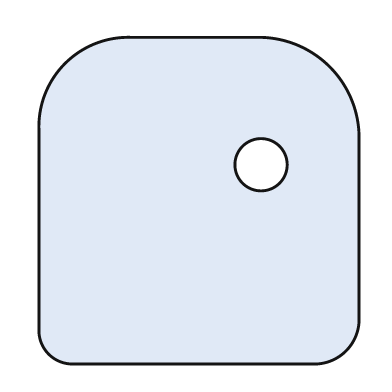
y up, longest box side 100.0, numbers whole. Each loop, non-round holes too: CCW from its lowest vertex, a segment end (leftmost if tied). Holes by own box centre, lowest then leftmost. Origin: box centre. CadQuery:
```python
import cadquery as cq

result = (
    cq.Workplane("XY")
    .moveTo(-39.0, -50.0)
    .lineTo(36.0, -50.0)
    .threePointArc((45.0, -46.0), (49.0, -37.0))
    .lineTo(49.0, 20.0)
    .threePointArc((40.0, 41.0), (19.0, 50.0))
    .lineTo(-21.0, 50.0)
    .threePointArc((-41.0, 42.0), (-49.0, 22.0))
    .lineTo(-49.0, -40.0)
    .threePointArc((-46.0, -47.0), (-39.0, -50.0))
    .close()
    .moveTo(19.0, 11.0)
    .circle(8.0)
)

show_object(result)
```